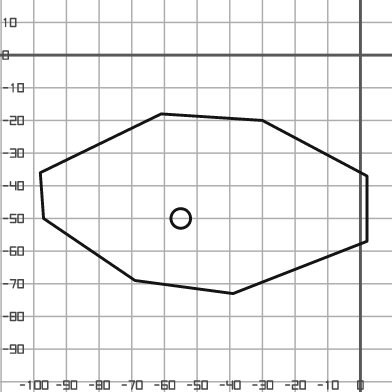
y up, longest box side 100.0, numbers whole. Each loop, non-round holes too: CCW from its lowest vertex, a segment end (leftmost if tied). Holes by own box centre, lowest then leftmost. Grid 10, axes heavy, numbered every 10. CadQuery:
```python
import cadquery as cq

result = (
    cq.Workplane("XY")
    .moveTo(-39.0, -73.0)
    .lineTo(2.0, -57.0)
    .lineTo(2.0, -37.0)
    .lineTo(-30.0, -20.0)
    .lineTo(-61.0, -18.0)
    .lineTo(-98.0, -36.0)
    .lineTo(-97.0, -50.0)
    .lineTo(-69.0, -69.0)
    .close()
    .moveTo(-55.0, -50.0)
    .circle(3.0)
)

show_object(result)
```